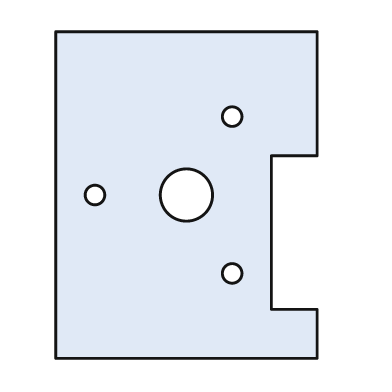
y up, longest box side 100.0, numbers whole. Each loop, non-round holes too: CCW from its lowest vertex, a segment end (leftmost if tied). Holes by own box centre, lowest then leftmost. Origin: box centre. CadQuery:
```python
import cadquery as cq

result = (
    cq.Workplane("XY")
    .moveTo(-40.0, -50.0)
    .lineTo(40.0, -50.0)
    .lineTo(40.0, -35.0)
    .lineTo(26.0, -35.0)
    .lineTo(26.0, 12.0)
    .lineTo(40.0, 12.0)
    .lineTo(40.0, 50.0)
    .lineTo(-40.0, 50.0)
    .close()
    .moveTo(14.0, -24.0)
    .circle(3.0)
    .moveTo(-28.0, 0.0)
    .circle(3.0)
    .moveTo(0.0, 0.0)
    .circle(8.0)
    .moveTo(14.0, 24.0)
    .circle(3.0)
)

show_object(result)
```